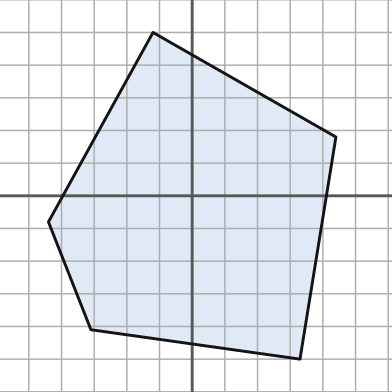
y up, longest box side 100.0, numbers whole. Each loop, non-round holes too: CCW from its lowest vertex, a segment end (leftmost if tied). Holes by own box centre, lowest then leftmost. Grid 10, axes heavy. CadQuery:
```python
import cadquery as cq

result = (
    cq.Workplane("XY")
    .moveTo(33.0, -50.0)
    .lineTo(44.0, 18.0)
    .lineTo(-12.0, 50.0)
    .lineTo(-44.0, -8.0)
    .lineTo(-31.0, -41.0)
    .close()
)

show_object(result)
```